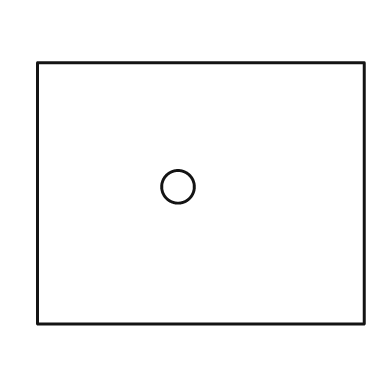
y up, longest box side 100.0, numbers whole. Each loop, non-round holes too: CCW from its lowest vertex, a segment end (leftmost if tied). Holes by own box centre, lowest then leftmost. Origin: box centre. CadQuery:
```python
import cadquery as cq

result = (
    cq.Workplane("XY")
    .moveTo(-50.0, -40.0)
    .lineTo(50.0, -40.0)
    .lineTo(50.0, 40.0)
    .lineTo(-50.0, 40.0)
    .close()
    .moveTo(-7.0, 2.0)
    .circle(5.0)
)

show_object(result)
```